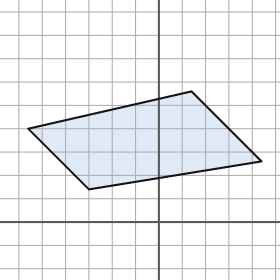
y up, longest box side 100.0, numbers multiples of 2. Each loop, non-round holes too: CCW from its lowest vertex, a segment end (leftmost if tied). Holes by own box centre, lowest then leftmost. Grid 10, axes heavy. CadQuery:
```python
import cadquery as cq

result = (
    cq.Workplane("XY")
    .moveTo(-30.0, 14.0)
    .lineTo(44.0, 26.0)
    .lineTo(14.0, 56.0)
    .lineTo(-56.0, 40.0)
    .close()
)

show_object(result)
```